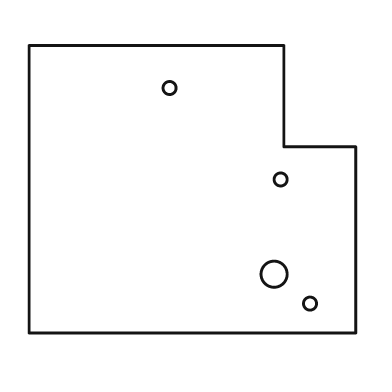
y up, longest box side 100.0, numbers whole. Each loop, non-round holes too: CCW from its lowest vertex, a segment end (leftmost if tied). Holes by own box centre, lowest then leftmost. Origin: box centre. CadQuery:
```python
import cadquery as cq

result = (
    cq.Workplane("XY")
    .moveTo(-50.0, -44.0)
    .lineTo(50.0, -44.0)
    .lineTo(50.0, 13.0)
    .lineTo(28.0, 13.0)
    .lineTo(28.0, 44.0)
    .lineTo(-50.0, 44.0)
    .close()
    .moveTo(36.0, -35.0)
    .circle(2.0)
    .moveTo(25.0, -26.0)
    .circle(4.0)
    .moveTo(27.0, 3.0)
    .circle(2.0)
    .moveTo(-7.0, 31.0)
    .circle(2.0)
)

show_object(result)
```